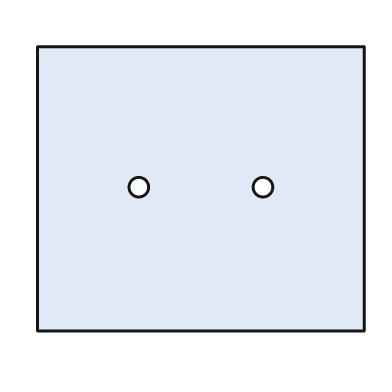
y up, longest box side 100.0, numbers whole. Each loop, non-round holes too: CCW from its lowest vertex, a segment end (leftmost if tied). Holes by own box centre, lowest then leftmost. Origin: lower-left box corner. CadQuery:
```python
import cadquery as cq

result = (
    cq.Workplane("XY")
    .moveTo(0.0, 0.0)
    .lineTo(100.0, 0.0)
    .lineTo(100.0, 87.0)
    .lineTo(0.0, 87.0)
    .close()
    .moveTo(31.0, 44.0)
    .circle(3.0)
    .moveTo(69.0, 44.0)
    .circle(3.0)
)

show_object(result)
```